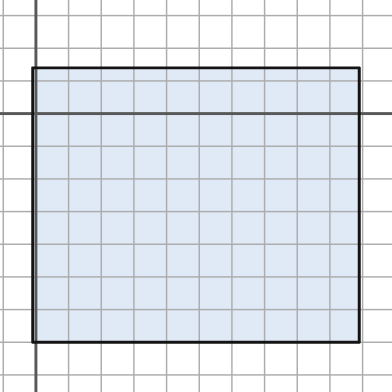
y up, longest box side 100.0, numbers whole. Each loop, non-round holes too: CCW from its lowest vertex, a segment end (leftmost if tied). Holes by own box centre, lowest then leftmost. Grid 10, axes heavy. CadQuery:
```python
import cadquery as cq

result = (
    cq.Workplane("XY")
    .moveTo(-1.0, -70.0)
    .lineTo(99.0, -70.0)
    .lineTo(99.0, 14.0)
    .lineTo(-1.0, 14.0)
    .close()
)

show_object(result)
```